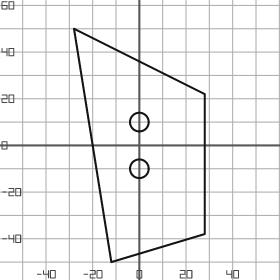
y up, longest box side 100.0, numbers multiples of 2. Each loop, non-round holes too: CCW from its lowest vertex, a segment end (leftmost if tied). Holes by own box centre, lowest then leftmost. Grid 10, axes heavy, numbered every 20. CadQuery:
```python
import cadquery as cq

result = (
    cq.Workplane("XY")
    .moveTo(-12.0, -50.0)
    .lineTo(28.0, -38.0)
    .lineTo(28.0, 22.0)
    .lineTo(-28.0, 50.0)
    .close()
    .moveTo(0.0, -10.0)
    .circle(4.0)
    .moveTo(0.0, 10.0)
    .circle(4.0)
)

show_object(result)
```